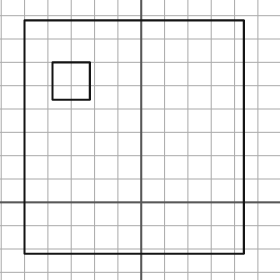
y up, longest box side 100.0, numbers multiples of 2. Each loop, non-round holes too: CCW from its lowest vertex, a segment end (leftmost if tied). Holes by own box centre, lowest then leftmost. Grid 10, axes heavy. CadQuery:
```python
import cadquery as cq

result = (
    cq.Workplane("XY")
    .moveTo(-50.0, -22.0)
    .lineTo(44.0, -22.0)
    .lineTo(44.0, 78.0)
    .lineTo(-50.0, 78.0)
    .close()
    .moveTo(-38.0, 44.0)
    .lineTo(-22.0, 44.0)
    .lineTo(-22.0, 60.0)
    .lineTo(-38.0, 60.0)
    .close()
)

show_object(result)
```